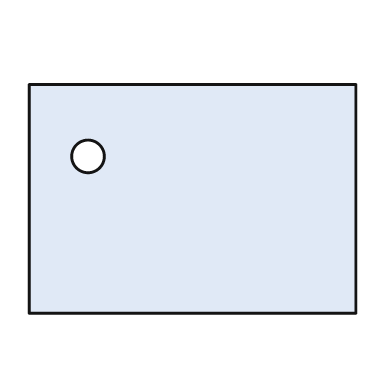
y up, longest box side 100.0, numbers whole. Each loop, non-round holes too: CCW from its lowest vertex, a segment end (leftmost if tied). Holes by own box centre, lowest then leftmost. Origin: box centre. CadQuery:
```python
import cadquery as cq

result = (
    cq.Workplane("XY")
    .moveTo(-50.0, -35.0)
    .lineTo(50.0, -35.0)
    .lineTo(50.0, 35.0)
    .lineTo(-50.0, 35.0)
    .close()
    .moveTo(-32.0, 13.0)
    .circle(5.0)
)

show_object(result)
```